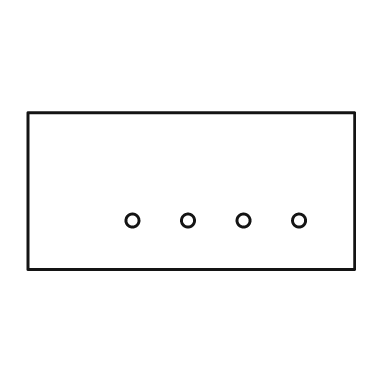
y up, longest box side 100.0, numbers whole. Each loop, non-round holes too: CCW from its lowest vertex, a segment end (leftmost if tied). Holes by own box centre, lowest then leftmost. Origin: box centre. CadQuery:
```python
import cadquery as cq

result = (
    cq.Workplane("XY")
    .moveTo(-50.0, -24.0)
    .lineTo(50.0, -24.0)
    .lineTo(50.0, 24.0)
    .lineTo(-50.0, 24.0)
    .close()
    .moveTo(-18.0, -9.0)
    .circle(2.0)
    .moveTo(-1.0, -9.0)
    .circle(2.0)
    .moveTo(16.0, -9.0)
    .circle(2.0)
    .moveTo(33.0, -9.0)
    .circle(2.0)
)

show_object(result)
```